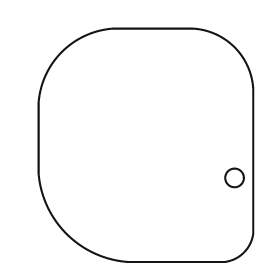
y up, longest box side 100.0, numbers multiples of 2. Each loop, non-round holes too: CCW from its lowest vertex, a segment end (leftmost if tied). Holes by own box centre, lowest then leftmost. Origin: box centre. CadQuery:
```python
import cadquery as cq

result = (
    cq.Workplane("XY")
    .moveTo(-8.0, -50.0)
    .lineTo(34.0, -50.0)
    .threePointArc((42.0, -46.0), (46.0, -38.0))
    .lineTo(46.0, 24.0)
    .threePointArc((38.0, 42.0), (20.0, 50.0))
    .lineTo(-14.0, 50.0)
    .threePointArc((-36.0, 40.0), (-46.0, 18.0))
    .lineTo(-46.0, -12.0)
    .threePointArc((-34.0, -38.0), (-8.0, -50.0))
    .close()
    .moveTo(38.0, -14.0)
    .circle(4.0)
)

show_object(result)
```